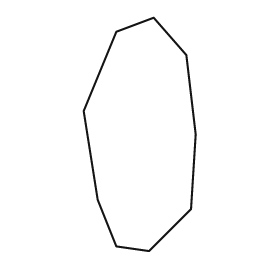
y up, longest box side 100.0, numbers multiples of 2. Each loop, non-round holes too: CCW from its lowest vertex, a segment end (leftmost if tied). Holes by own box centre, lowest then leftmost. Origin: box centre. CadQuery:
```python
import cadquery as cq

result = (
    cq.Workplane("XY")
    .moveTo(4.0, -50.0)
    .lineTo(22.0, -32.0)
    .lineTo(24.0, 0.0)
    .lineTo(20.0, 34.0)
    .lineTo(6.0, 50.0)
    .lineTo(-10.0, 44.0)
    .lineTo(-24.0, 10.0)
    .lineTo(-18.0, -28.0)
    .lineTo(-10.0, -48.0)
    .close()
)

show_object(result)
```